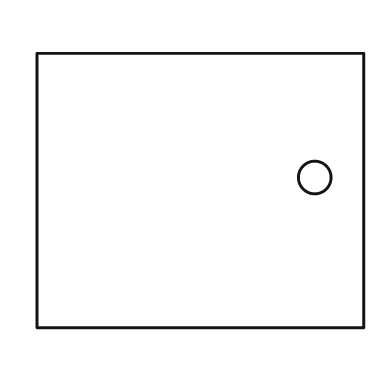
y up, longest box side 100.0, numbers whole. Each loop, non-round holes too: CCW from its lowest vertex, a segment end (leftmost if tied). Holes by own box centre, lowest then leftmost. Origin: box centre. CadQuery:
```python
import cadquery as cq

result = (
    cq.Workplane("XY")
    .moveTo(-50.0, -42.0)
    .lineTo(50.0, -42.0)
    .lineTo(50.0, 42.0)
    .lineTo(-50.0, 42.0)
    .close()
    .moveTo(35.0, 4.0)
    .circle(5.0)
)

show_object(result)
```